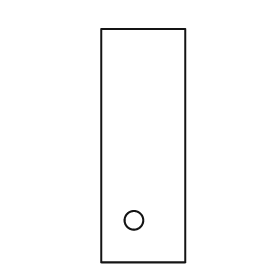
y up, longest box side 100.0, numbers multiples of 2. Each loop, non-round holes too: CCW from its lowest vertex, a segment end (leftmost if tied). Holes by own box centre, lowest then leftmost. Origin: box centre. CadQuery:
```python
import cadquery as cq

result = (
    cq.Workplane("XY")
    .moveTo(-18.0, -50.0)
    .lineTo(18.0, -50.0)
    .lineTo(18.0, 50.0)
    .lineTo(-18.0, 50.0)
    .close()
    .moveTo(-4.0, -32.0)
    .circle(4.0)
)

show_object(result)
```